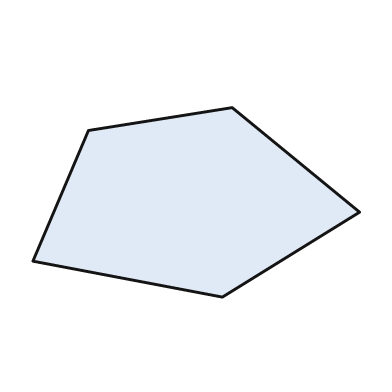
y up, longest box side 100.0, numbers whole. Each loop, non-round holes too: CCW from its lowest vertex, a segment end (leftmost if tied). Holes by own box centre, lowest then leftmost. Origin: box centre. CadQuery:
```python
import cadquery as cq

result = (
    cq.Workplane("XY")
    .moveTo(8.0, -29.0)
    .lineTo(50.0, -3.0)
    .lineTo(11.0, 29.0)
    .lineTo(-33.0, 22.0)
    .lineTo(-50.0, -18.0)
    .close()
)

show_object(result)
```